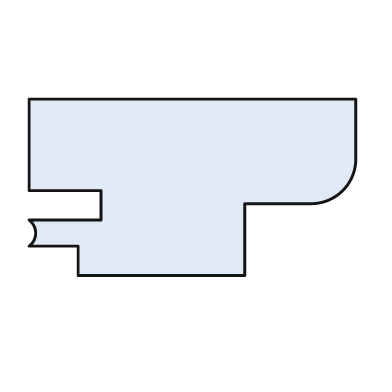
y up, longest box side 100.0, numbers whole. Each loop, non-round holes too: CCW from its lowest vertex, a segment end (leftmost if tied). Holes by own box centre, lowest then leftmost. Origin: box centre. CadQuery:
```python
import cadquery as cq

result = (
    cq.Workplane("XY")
    .moveTo(-35.0, -27.0)
    .lineTo(16.0, -27.0)
    .lineTo(16.0, -5.0)
    .lineTo(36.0, -5.0)
    .threePointArc((46.0, -1.0), (50.0, 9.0))
    .lineTo(50.0, 27.0)
    .lineTo(-50.0, 27.0)
    .lineTo(-50.0, -1.0)
    .lineTo(-28.0, -1.0)
    .lineTo(-28.0, -10.0)
    .lineTo(-50.0, -10.0)
    .threePointArc((-48.0, -14.0), (-50.0, -18.0))
    .lineTo(-35.0, -18.0)
    .close()
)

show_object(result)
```